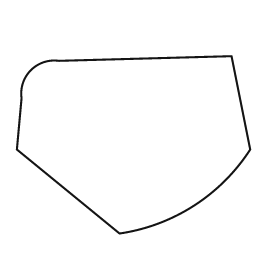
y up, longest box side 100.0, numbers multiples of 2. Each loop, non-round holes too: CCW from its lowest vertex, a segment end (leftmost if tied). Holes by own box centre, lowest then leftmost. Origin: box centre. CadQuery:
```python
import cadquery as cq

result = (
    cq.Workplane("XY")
    .moveTo(-6.0, -38.0)
    .threePointArc((26.0, -26.0), (50.0, -2.0))
    .lineTo(42.0, 38.0)
    .lineTo(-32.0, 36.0)
    .threePointArc((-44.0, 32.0), (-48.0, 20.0))
    .lineTo(-50.0, -2.0)
    .close()
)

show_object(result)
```